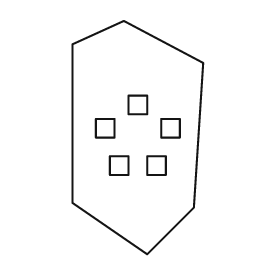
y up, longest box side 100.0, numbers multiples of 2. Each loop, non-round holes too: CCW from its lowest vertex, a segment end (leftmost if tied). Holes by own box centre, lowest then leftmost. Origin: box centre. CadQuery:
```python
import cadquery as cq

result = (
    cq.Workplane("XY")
    .moveTo(4.0, -50.0)
    .lineTo(24.0, -30.0)
    .lineTo(28.0, 32.0)
    .lineTo(-6.0, 50.0)
    .lineTo(-28.0, 40.0)
    .lineTo(-28.0, -28.0)
    .close()
    .moveTo(-12.0, -16.0)
    .lineTo(-4.0, -16.0)
    .lineTo(-4.0, -8.0)
    .lineTo(-12.0, -8.0)
    .close()
    .moveTo(4.0, -16.0)
    .lineTo(12.0, -16.0)
    .lineTo(12.0, -8.0)
    .lineTo(4.0, -8.0)
    .close()
    .moveTo(-18.0, 0.0)
    .lineTo(-10.0, 0.0)
    .lineTo(-10.0, 8.0)
    .lineTo(-18.0, 8.0)
    .close()
    .moveTo(10.0, 0.0)
    .lineTo(18.0, 0.0)
    .lineTo(18.0, 8.0)
    .lineTo(10.0, 8.0)
    .close()
    .moveTo(-4.0, 10.0)
    .lineTo(4.0, 10.0)
    .lineTo(4.0, 18.0)
    .lineTo(-4.0, 18.0)
    .close()
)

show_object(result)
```